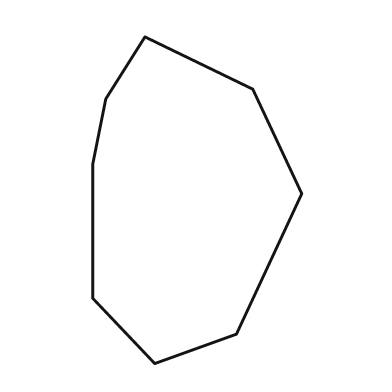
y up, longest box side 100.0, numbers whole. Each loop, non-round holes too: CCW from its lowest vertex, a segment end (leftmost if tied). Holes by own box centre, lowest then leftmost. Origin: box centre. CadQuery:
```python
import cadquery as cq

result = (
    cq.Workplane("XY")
    .moveTo(-13.0, -50.0)
    .lineTo(12.0, -41.0)
    .lineTo(32.0, 2.0)
    .lineTo(17.0, 34.0)
    .lineTo(-16.0, 50.0)
    .lineTo(-28.0, 31.0)
    .lineTo(-32.0, 11.0)
    .lineTo(-32.0, -30.0)
    .close()
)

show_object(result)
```